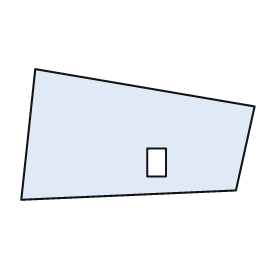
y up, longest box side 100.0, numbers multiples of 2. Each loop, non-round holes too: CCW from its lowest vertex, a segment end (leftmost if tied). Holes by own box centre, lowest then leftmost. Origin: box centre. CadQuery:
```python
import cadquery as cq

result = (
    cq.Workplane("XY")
    .moveTo(-50.0, -28.0)
    .lineTo(42.0, -24.0)
    .lineTo(50.0, 12.0)
    .lineTo(-44.0, 28.0)
    .close()
    .moveTo(4.0, -18.0)
    .lineTo(12.0, -18.0)
    .lineTo(12.0, -6.0)
    .lineTo(4.0, -6.0)
    .close()
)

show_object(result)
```